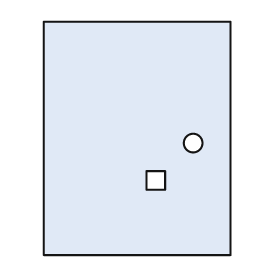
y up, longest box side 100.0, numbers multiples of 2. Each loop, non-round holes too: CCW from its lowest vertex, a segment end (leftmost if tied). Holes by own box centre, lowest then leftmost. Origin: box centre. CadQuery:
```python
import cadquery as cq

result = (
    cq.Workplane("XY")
    .moveTo(-40.0, -50.0)
    .lineTo(40.0, -50.0)
    .lineTo(40.0, 50.0)
    .lineTo(-40.0, 50.0)
    .close()
    .moveTo(4.0, -22.0)
    .lineTo(12.0, -22.0)
    .lineTo(12.0, -14.0)
    .lineTo(4.0, -14.0)
    .close()
    .moveTo(24.0, -2.0)
    .circle(4.0)
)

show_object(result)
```